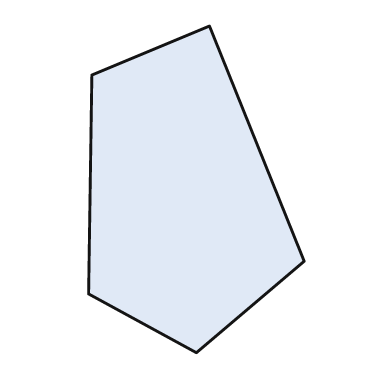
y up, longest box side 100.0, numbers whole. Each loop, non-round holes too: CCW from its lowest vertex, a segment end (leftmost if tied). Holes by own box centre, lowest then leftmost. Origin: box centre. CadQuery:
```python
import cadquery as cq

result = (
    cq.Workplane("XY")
    .moveTo(0.0, -50.0)
    .lineTo(33.0, -22.0)
    .lineTo(4.0, 50.0)
    .lineTo(-32.0, 35.0)
    .lineTo(-33.0, -32.0)
    .close()
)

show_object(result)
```